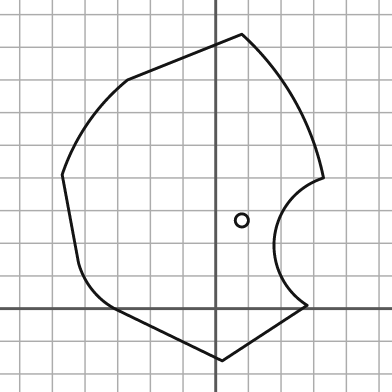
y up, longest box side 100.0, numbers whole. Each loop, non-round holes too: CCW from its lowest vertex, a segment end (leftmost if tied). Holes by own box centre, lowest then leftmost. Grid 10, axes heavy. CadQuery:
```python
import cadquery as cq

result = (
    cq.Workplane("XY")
    .moveTo(2.0, -16.0)
    .lineTo(28.0, 1.0)
    .threePointArc((18.0, 22.0), (33.0, 40.0))
    .threePointArc((24.0, 64.0), (8.0, 84.0))
    .lineTo(-27.0, 70.0)
    .threePointArc((-39.0, 57.0), (-47.0, 41.0))
    .lineTo(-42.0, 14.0)
    .threePointArc((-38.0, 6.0), (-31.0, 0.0))
    .close()
    .moveTo(8.0, 27.0)
    .circle(2.0)
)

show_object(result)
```